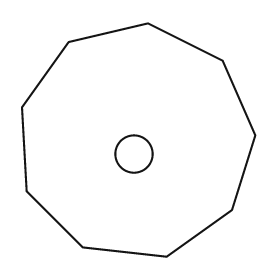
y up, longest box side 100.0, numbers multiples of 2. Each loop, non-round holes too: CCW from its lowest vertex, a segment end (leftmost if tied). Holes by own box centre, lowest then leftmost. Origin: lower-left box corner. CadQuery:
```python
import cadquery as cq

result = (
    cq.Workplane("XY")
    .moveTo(62.0, 0.0)
    .lineTo(90.0, 20.0)
    .lineTo(100.0, 52.0)
    .lineTo(86.0, 84.0)
    .lineTo(54.0, 100.0)
    .lineTo(20.0, 92.0)
    .lineTo(0.0, 64.0)
    .lineTo(2.0, 28.0)
    .lineTo(26.0, 4.0)
    .close()
    .moveTo(48.0, 44.0)
    .circle(8.0)
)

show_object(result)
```